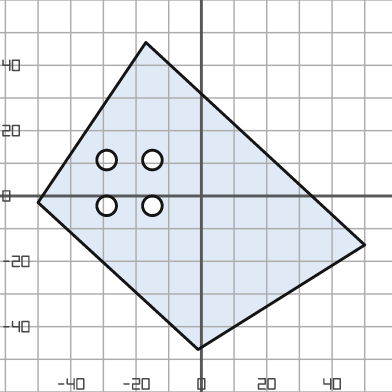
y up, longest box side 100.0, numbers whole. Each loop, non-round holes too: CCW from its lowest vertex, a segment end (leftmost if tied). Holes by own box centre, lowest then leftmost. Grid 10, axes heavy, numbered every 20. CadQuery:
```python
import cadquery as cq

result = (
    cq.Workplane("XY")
    .moveTo(-1.0, -47.0)
    .lineTo(50.0, -15.0)
    .lineTo(-17.0, 47.0)
    .lineTo(-50.0, -2.0)
    .close()
    .moveTo(-29.0, -3.0)
    .circle(3.0)
    .moveTo(-15.0, -3.0)
    .circle(3.0)
    .moveTo(-29.0, 11.0)
    .circle(3.0)
    .moveTo(-15.0, 11.0)
    .circle(3.0)
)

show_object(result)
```